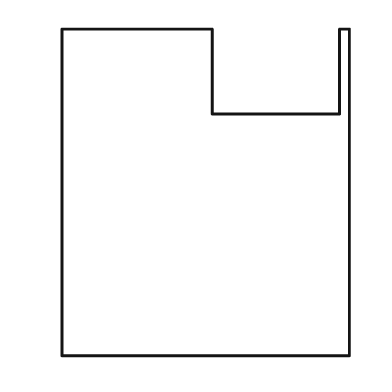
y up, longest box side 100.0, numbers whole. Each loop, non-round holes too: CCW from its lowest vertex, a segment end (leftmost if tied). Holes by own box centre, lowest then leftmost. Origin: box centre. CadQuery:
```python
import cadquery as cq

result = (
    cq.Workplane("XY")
    .moveTo(-44.0, -50.0)
    .lineTo(44.0, -50.0)
    .lineTo(44.0, 50.0)
    .lineTo(41.0, 50.0)
    .lineTo(41.0, 24.0)
    .lineTo(2.0, 24.0)
    .lineTo(2.0, 50.0)
    .lineTo(-44.0, 50.0)
    .close()
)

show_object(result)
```